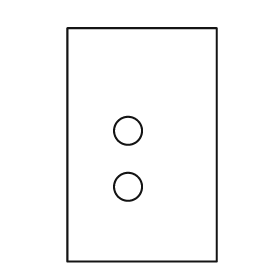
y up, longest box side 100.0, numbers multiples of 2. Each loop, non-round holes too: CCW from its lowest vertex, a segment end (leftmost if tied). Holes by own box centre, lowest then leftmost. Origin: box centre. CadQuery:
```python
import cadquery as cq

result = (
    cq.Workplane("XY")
    .moveTo(-32.0, -50.0)
    .lineTo(32.0, -50.0)
    .lineTo(32.0, 50.0)
    .lineTo(-32.0, 50.0)
    .close()
    .moveTo(-6.0, -18.0)
    .circle(6.0)
    .moveTo(-6.0, 6.0)
    .circle(6.0)
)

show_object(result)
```